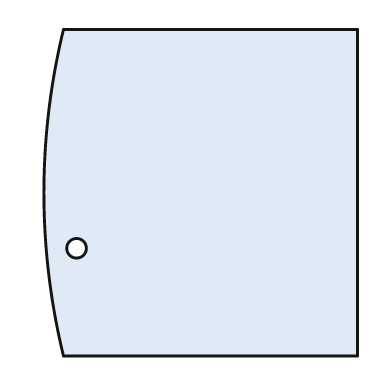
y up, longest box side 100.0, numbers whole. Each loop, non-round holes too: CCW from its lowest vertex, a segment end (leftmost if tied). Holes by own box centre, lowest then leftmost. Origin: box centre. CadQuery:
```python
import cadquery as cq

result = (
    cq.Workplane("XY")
    .moveTo(-42.0, -50.0)
    .lineTo(48.0, -50.0)
    .lineTo(48.0, 50.0)
    .lineTo(-42.0, 50.0)
    .threePointArc((-48.0, 0.0), (-42.0, -50.0))
    .close()
    .moveTo(-38.0, -17.0)
    .circle(3.0)
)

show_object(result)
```